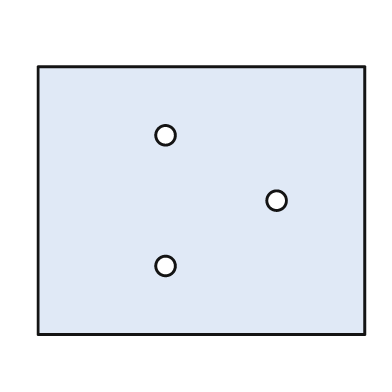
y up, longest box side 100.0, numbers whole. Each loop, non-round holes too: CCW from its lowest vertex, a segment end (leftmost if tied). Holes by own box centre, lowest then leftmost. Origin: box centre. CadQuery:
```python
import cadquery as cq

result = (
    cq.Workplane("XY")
    .moveTo(-50.0, -41.0)
    .lineTo(50.0, -41.0)
    .lineTo(50.0, 41.0)
    .lineTo(-50.0, 41.0)
    .close()
    .moveTo(-11.0, -20.0)
    .circle(3.0)
    .moveTo(23.0, 0.0)
    .circle(3.0)
    .moveTo(-11.0, 20.0)
    .circle(3.0)
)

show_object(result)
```